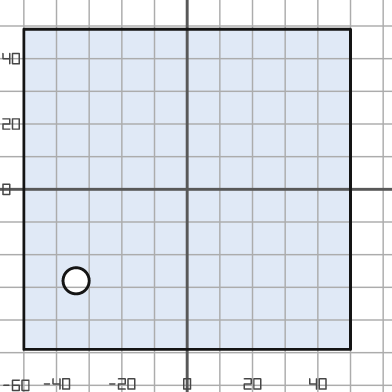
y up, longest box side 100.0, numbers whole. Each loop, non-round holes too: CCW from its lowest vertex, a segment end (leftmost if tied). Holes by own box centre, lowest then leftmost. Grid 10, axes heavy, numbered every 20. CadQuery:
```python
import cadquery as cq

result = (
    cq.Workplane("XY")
    .moveTo(-50.0, -49.0)
    .lineTo(50.0, -49.0)
    .lineTo(50.0, 49.0)
    .lineTo(-50.0, 49.0)
    .close()
    .moveTo(-34.0, -28.0)
    .circle(4.0)
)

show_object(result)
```